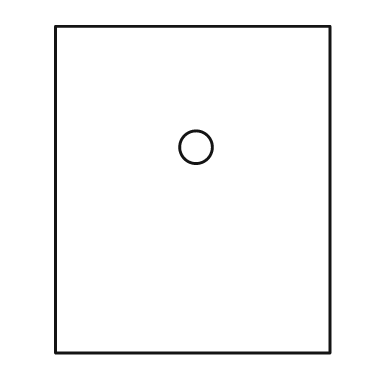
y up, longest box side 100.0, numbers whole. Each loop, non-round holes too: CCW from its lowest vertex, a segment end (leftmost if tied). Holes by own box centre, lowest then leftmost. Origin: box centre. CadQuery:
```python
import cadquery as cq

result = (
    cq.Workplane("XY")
    .moveTo(-42.0, -50.0)
    .lineTo(42.0, -50.0)
    .lineTo(42.0, 50.0)
    .lineTo(-42.0, 50.0)
    .close()
    .moveTo(1.0, 13.0)
    .circle(5.0)
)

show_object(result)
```